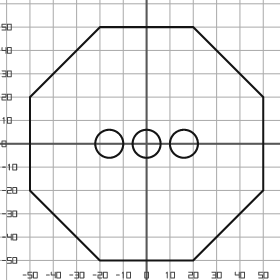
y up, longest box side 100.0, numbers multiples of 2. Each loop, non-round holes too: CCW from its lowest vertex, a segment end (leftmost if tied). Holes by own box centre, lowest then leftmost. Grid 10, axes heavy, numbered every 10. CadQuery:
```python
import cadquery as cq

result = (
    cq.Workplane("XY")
    .moveTo(-20.0, -50.0)
    .lineTo(20.0, -50.0)
    .lineTo(50.0, -20.0)
    .lineTo(50.0, 20.0)
    .lineTo(20.0, 50.0)
    .lineTo(-20.0, 50.0)
    .lineTo(-50.0, 20.0)
    .lineTo(-50.0, -20.0)
    .close()
    .moveTo(-16.0, 0.0)
    .circle(6.0)
    .moveTo(0.0, 0.0)
    .circle(6.0)
    .moveTo(16.0, 0.0)
    .circle(6.0)
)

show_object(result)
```